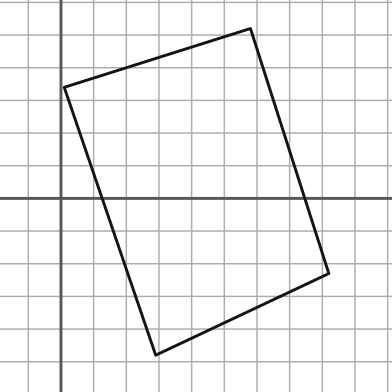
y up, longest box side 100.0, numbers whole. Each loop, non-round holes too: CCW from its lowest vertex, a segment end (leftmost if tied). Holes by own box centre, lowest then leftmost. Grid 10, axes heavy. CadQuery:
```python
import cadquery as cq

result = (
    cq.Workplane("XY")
    .moveTo(29.0, -48.0)
    .lineTo(82.0, -23.0)
    .lineTo(58.0, 52.0)
    .lineTo(1.0, 34.0)
    .close()
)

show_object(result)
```